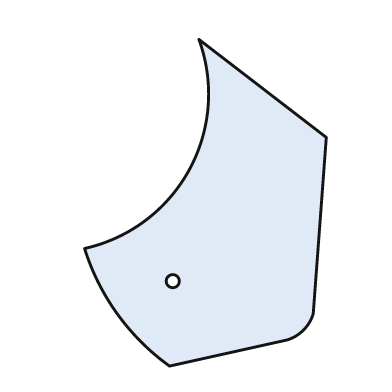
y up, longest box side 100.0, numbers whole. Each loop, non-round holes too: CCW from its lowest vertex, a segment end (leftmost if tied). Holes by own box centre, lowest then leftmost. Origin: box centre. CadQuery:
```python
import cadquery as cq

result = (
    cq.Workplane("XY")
    .moveTo(-11.0, -50.0)
    .lineTo(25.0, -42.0)
    .threePointArc((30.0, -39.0), (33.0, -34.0))
    .lineTo(37.0, 20.0)
    .lineTo(-2.0, 50.0)
    .threePointArc((-5.0, 10.0), (-37.0, -14.0))
    .threePointArc((-27.0, -34.0), (-11.0, -50.0))
    .close()
    .moveTo(-10.0, -24.0)
    .circle(2.0)
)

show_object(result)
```